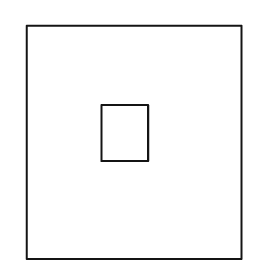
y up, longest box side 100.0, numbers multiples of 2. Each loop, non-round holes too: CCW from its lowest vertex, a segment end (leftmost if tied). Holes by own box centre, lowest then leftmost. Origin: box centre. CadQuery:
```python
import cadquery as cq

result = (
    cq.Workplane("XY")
    .moveTo(-46.0, -50.0)
    .lineTo(46.0, -50.0)
    .lineTo(46.0, 50.0)
    .lineTo(-46.0, 50.0)
    .close()
    .moveTo(-14.0, -8.0)
    .lineTo(6.0, -8.0)
    .lineTo(6.0, 16.0)
    .lineTo(-14.0, 16.0)
    .close()
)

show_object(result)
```